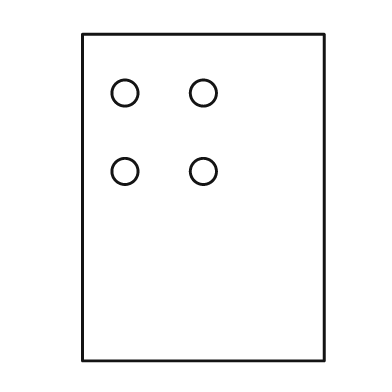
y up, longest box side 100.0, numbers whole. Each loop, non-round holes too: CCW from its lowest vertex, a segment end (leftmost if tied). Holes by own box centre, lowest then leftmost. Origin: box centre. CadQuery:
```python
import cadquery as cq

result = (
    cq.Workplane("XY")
    .moveTo(-37.0, -50.0)
    .lineTo(37.0, -50.0)
    .lineTo(37.0, 50.0)
    .lineTo(-37.0, 50.0)
    .close()
    .moveTo(-24.0, 8.0)
    .circle(4.0)
    .moveTo(0.0, 8.0)
    .circle(4.0)
    .moveTo(-24.0, 32.0)
    .circle(4.0)
    .moveTo(0.0, 32.0)
    .circle(4.0)
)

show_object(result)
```